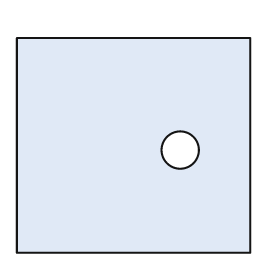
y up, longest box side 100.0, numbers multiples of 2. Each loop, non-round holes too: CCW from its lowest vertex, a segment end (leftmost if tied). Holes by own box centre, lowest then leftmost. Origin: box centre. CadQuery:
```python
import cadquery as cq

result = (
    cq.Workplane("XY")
    .moveTo(-50.0, -46.0)
    .lineTo(50.0, -46.0)
    .lineTo(50.0, 46.0)
    .lineTo(-50.0, 46.0)
    .close()
    .moveTo(20.0, -2.0)
    .circle(8.0)
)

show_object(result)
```